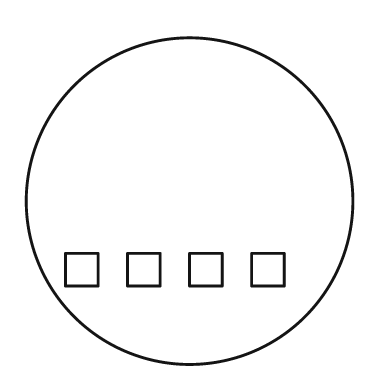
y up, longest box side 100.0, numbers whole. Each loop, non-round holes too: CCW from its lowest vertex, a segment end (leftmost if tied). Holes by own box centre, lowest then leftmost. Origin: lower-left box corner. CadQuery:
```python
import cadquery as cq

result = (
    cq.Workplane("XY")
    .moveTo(50.0, 50.0)
    .circle(50.0)
    .moveTo(12.0, 24.0)
    .lineTo(22.0, 24.0)
    .lineTo(22.0, 34.0)
    .lineTo(12.0, 34.0)
    .close()
    .moveTo(31.0, 24.0)
    .lineTo(41.0, 24.0)
    .lineTo(41.0, 34.0)
    .lineTo(31.0, 34.0)
    .close()
    .moveTo(50.0, 24.0)
    .lineTo(60.0, 24.0)
    .lineTo(60.0, 34.0)
    .lineTo(50.0, 34.0)
    .close()
    .moveTo(69.0, 24.0)
    .lineTo(79.0, 24.0)
    .lineTo(79.0, 34.0)
    .lineTo(69.0, 34.0)
    .close()
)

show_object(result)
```